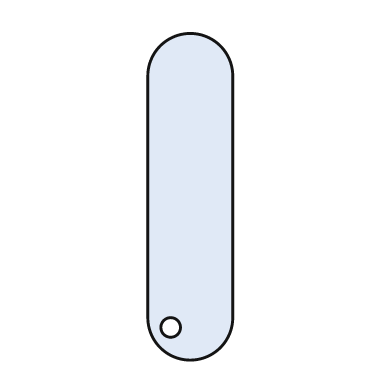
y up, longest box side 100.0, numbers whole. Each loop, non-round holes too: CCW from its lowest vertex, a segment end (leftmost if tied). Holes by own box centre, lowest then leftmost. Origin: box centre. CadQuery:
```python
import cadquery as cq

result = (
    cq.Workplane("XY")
    .moveTo(-13.0, -37.0)
    .threePointArc((0.0, -50.0), (13.0, -37.0))
    .lineTo(13.0, 37.0)
    .threePointArc((0.0, 50.0), (-13.0, 37.0))
    .close()
    .moveTo(-6.0, -40.0)
    .circle(3.0)
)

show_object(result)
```